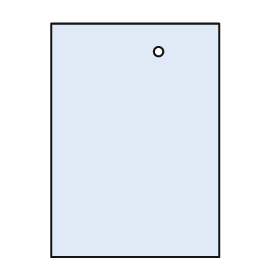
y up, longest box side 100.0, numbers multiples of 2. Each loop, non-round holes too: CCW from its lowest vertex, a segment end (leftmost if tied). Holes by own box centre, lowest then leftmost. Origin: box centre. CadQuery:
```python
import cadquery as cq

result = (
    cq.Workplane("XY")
    .moveTo(-36.0, -50.0)
    .lineTo(36.0, -50.0)
    .lineTo(36.0, 50.0)
    .lineTo(-36.0, 50.0)
    .close()
    .moveTo(10.0, 38.0)
    .circle(2.0)
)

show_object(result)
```